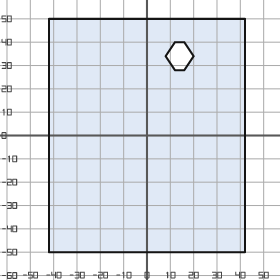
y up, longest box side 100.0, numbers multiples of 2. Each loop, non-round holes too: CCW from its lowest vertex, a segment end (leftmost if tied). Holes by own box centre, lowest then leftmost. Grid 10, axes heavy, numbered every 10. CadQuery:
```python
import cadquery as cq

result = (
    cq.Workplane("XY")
    .moveTo(-42.0, -50.0)
    .lineTo(42.0, -50.0)
    .lineTo(42.0, 50.0)
    .lineTo(-42.0, 50.0)
    .close()
    .moveTo(12.0, 28.0)
    .lineTo(16.0, 28.0)
    .lineTo(20.0, 34.0)
    .lineTo(16.0, 40.0)
    .lineTo(12.0, 40.0)
    .lineTo(8.0, 34.0)
    .close()
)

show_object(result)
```